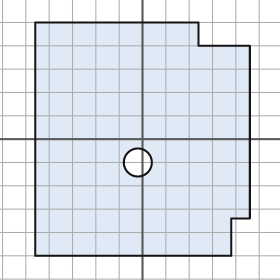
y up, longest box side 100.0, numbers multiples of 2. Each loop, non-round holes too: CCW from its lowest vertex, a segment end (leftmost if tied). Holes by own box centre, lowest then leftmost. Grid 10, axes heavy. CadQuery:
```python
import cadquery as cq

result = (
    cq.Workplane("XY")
    .moveTo(-46.0, -50.0)
    .lineTo(38.0, -50.0)
    .lineTo(38.0, -34.0)
    .lineTo(46.0, -34.0)
    .lineTo(46.0, 40.0)
    .lineTo(24.0, 40.0)
    .lineTo(24.0, 50.0)
    .lineTo(-46.0, 50.0)
    .close()
    .moveTo(-2.0, -10.0)
    .circle(6.0)
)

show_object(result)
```